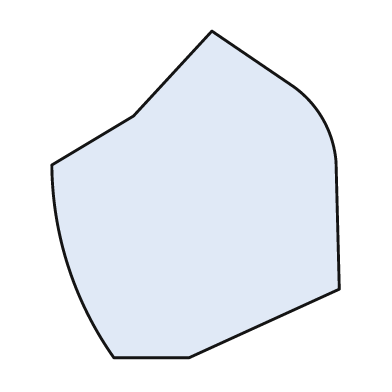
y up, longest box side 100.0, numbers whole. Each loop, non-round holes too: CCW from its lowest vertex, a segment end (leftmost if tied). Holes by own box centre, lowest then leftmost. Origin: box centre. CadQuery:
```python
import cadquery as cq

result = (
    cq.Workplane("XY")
    .moveTo(-25.0, -50.0)
    .lineTo(-2.0, -50.0)
    .lineTo(44.0, -29.0)
    .lineTo(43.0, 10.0)
    .threePointArc((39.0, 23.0), (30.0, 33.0))
    .lineTo(5.0, 50.0)
    .lineTo(-19.0, 24.0)
    .lineTo(-44.0, 9.0)
    .threePointArc((-39.0, -22.0), (-25.0, -50.0))
    .close()
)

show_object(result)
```